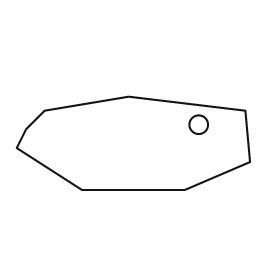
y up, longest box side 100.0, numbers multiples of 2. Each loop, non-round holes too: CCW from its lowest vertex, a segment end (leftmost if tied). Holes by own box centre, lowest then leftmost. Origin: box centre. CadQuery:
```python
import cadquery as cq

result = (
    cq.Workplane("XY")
    .moveTo(-22.0, -20.0)
    .lineTo(22.0, -20.0)
    .lineTo(50.0, -8.0)
    .lineTo(48.0, 14.0)
    .lineTo(-2.0, 20.0)
    .lineTo(-38.0, 14.0)
    .lineTo(-46.0, 6.0)
    .lineTo(-50.0, -2.0)
    .close()
    .moveTo(28.0, 8.0)
    .circle(4.0)
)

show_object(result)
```